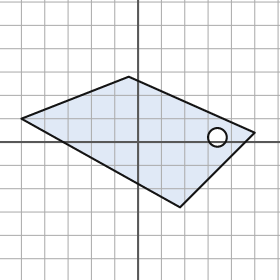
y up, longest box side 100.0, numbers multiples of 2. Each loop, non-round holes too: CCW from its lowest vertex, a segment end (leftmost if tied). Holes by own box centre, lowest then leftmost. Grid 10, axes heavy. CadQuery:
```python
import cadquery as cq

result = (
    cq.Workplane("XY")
    .moveTo(18.0, -28.0)
    .lineTo(50.0, 4.0)
    .lineTo(-4.0, 28.0)
    .lineTo(-50.0, 10.0)
    .close()
    .moveTo(34.0, 2.0)
    .circle(4.0)
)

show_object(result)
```